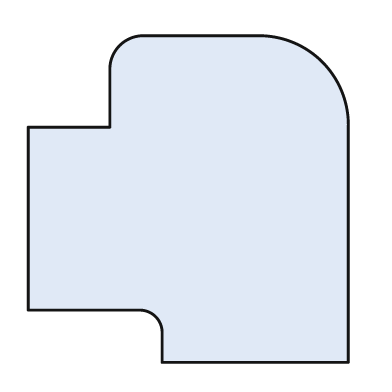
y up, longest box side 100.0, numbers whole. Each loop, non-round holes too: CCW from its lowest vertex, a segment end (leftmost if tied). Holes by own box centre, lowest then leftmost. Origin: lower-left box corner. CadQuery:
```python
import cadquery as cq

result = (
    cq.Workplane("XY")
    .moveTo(41.0, 0.0)
    .lineTo(98.0, 0.0)
    .lineTo(98.0, 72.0)
    .threePointArc((90.0, 92.0), (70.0, 100.0))
    .lineTo(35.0, 100.0)
    .threePointArc((28.0, 97.0), (25.0, 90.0))
    .lineTo(25.0, 72.0)
    .lineTo(0.0, 72.0)
    .lineTo(0.0, 16.0)
    .lineTo(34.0, 16.0)
    .threePointArc((39.0, 14.0), (41.0, 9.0))
    .close()
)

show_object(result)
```